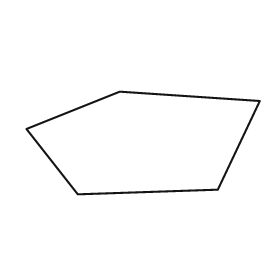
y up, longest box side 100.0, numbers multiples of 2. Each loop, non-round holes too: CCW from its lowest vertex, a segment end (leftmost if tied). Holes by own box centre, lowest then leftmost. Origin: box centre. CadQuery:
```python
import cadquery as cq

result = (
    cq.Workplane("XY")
    .moveTo(-28.0, -22.0)
    .lineTo(32.0, -20.0)
    .lineTo(50.0, 18.0)
    .lineTo(-10.0, 22.0)
    .lineTo(-50.0, 6.0)
    .close()
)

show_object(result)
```